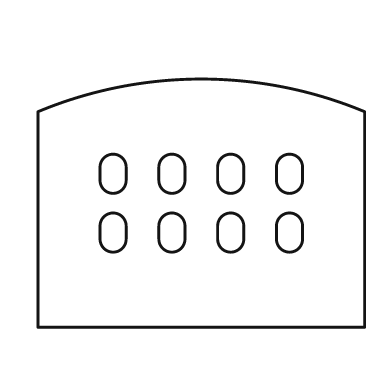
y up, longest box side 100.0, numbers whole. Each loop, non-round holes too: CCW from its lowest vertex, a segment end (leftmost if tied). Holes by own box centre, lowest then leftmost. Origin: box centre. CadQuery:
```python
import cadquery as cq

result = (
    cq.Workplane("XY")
    .moveTo(-50.0, -38.0)
    .lineTo(50.0, -38.0)
    .lineTo(50.0, 28.0)
    .threePointArc((0.0, 38.0), (-50.0, 28.0))
    .close()
    .moveTo(-31.0, -11.0)
    .threePointArc((-27.0, -15.0), (-23.0, -11.0))
    .lineTo(-23.0, -7.0)
    .threePointArc((-27.0, -3.0), (-31.0, -7.0))
    .close()
    .moveTo(-13.0, -11.0)
    .threePointArc((-9.0, -15.0), (-5.0, -11.0))
    .lineTo(-5.0, -7.0)
    .threePointArc((-9.0, -3.0), (-13.0, -7.0))
    .close()
    .moveTo(5.0, -11.0)
    .threePointArc((9.0, -15.0), (13.0, -11.0))
    .lineTo(13.0, -7.0)
    .threePointArc((9.0, -3.0), (5.0, -7.0))
    .close()
    .moveTo(23.0, -11.0)
    .threePointArc((27.0, -15.0), (31.0, -11.0))
    .lineTo(31.0, -7.0)
    .threePointArc((27.0, -3.0), (23.0, -7.0))
    .close()
    .moveTo(-31.0, 7.0)
    .threePointArc((-27.0, 3.0), (-23.0, 7.0))
    .lineTo(-23.0, 11.0)
    .threePointArc((-27.0, 15.0), (-31.0, 11.0))
    .close()
    .moveTo(-13.0, 7.0)
    .threePointArc((-9.0, 3.0), (-5.0, 7.0))
    .lineTo(-5.0, 11.0)
    .threePointArc((-9.0, 15.0), (-13.0, 11.0))
    .close()
    .moveTo(5.0, 7.0)
    .threePointArc((9.0, 3.0), (13.0, 7.0))
    .lineTo(13.0, 11.0)
    .threePointArc((9.0, 15.0), (5.0, 11.0))
    .close()
    .moveTo(23.0, 7.0)
    .threePointArc((27.0, 3.0), (31.0, 7.0))
    .lineTo(31.0, 11.0)
    .threePointArc((27.0, 15.0), (23.0, 11.0))
    .close()
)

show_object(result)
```